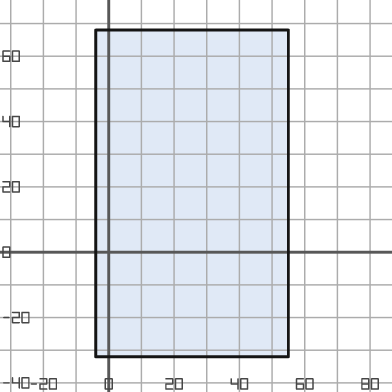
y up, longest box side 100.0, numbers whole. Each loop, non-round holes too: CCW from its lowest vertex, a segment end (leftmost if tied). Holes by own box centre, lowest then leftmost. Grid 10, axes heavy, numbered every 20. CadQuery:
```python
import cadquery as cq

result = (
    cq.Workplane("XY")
    .moveTo(-4.0, -32.0)
    .lineTo(55.0, -32.0)
    .lineTo(55.0, 68.0)
    .lineTo(-4.0, 68.0)
    .close()
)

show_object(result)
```